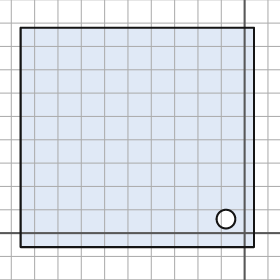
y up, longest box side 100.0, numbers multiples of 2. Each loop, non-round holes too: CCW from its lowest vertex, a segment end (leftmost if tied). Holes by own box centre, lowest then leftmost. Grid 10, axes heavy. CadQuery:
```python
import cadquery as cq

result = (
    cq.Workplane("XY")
    .moveTo(-96.0, -6.0)
    .lineTo(4.0, -6.0)
    .lineTo(4.0, 88.0)
    .lineTo(-96.0, 88.0)
    .close()
    .moveTo(-8.0, 6.0)
    .circle(4.0)
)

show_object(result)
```